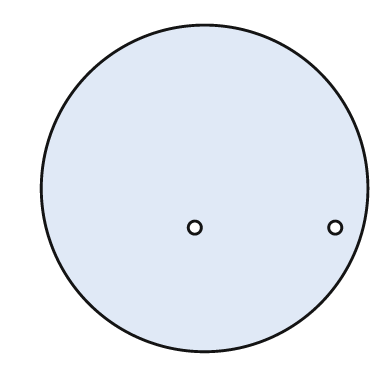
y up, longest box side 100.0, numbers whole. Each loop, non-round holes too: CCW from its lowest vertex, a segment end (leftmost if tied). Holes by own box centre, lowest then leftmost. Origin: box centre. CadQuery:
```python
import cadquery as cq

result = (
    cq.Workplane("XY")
    .moveTo(0.0, 0.0)
    .circle(50.0)
    .moveTo(-3.0, -12.0)
    .circle(2.0)
    .moveTo(40.0, -12.0)
    .circle(2.0)
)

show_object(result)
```